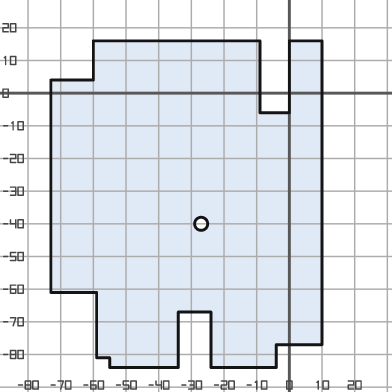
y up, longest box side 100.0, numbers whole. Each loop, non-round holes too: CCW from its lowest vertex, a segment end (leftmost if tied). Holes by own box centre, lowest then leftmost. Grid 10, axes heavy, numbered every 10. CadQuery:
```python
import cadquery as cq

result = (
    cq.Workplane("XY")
    .moveTo(-55.0, -84.0)
    .lineTo(-34.0, -84.0)
    .lineTo(-34.0, -67.0)
    .lineTo(-24.0, -67.0)
    .lineTo(-24.0, -84.0)
    .lineTo(-4.0, -84.0)
    .lineTo(-4.0, -77.0)
    .lineTo(10.0, -77.0)
    .lineTo(10.0, 16.0)
    .lineTo(0.0, 16.0)
    .lineTo(0.0, -6.0)
    .lineTo(-9.0, -6.0)
    .lineTo(-9.0, 16.0)
    .lineTo(-60.0, 16.0)
    .lineTo(-60.0, 4.0)
    .lineTo(-73.0, 4.0)
    .lineTo(-73.0, -61.0)
    .lineTo(-59.0, -61.0)
    .lineTo(-59.0, -81.0)
    .lineTo(-55.0, -81.0)
    .close()
    .moveTo(-27.0, -40.0)
    .circle(2.0)
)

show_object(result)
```